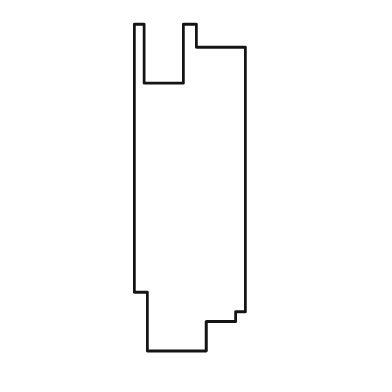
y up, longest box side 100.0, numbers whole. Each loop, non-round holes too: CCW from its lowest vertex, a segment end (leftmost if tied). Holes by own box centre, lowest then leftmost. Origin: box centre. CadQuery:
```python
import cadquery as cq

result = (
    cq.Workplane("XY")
    .moveTo(-13.0, -50.0)
    .lineTo(5.0, -50.0)
    .lineTo(5.0, -41.0)
    .lineTo(14.0, -41.0)
    .lineTo(14.0, -38.0)
    .lineTo(17.0, -38.0)
    .lineTo(17.0, 43.0)
    .lineTo(2.0, 43.0)
    .lineTo(2.0, 50.0)
    .lineTo(-2.0, 50.0)
    .lineTo(-2.0, 32.0)
    .lineTo(-14.0, 32.0)
    .lineTo(-14.0, 50.0)
    .lineTo(-17.0, 50.0)
    .lineTo(-17.0, -32.0)
    .lineTo(-13.0, -32.0)
    .close()
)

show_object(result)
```